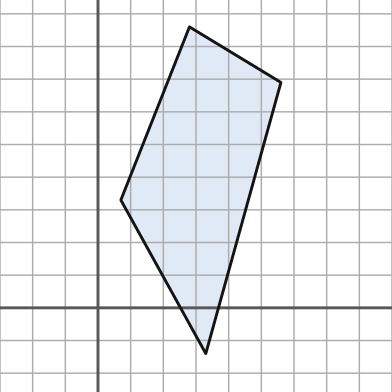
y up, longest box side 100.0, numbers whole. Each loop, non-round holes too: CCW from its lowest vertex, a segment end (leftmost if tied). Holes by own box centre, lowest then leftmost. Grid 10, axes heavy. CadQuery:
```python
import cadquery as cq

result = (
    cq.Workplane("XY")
    .moveTo(33.0, -14.0)
    .lineTo(56.0, 69.0)
    .lineTo(28.0, 86.0)
    .lineTo(7.0, 33.0)
    .close()
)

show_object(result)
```